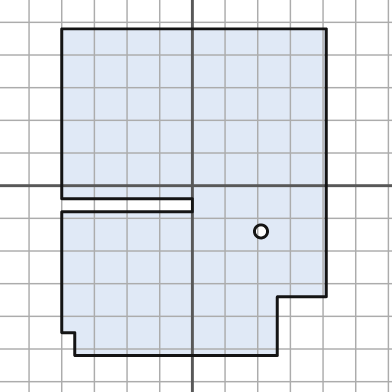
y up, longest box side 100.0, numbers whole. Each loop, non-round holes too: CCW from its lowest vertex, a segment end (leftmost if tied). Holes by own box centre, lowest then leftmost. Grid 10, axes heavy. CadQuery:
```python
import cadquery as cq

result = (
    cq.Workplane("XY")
    .moveTo(-36.0, -52.0)
    .lineTo(26.0, -52.0)
    .lineTo(26.0, -34.0)
    .lineTo(41.0, -34.0)
    .lineTo(41.0, 48.0)
    .lineTo(-40.0, 48.0)
    .lineTo(-40.0, -4.0)
    .lineTo(0.0, -4.0)
    .lineTo(0.0, -8.0)
    .lineTo(-40.0, -8.0)
    .lineTo(-40.0, -45.0)
    .lineTo(-36.0, -45.0)
    .close()
    .moveTo(21.0, -14.0)
    .circle(2.0)
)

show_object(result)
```